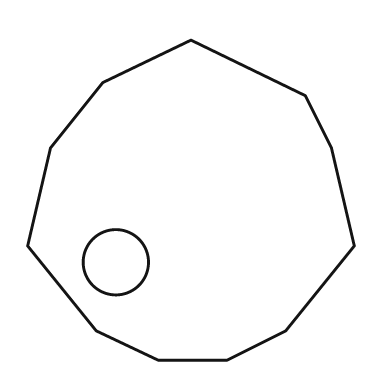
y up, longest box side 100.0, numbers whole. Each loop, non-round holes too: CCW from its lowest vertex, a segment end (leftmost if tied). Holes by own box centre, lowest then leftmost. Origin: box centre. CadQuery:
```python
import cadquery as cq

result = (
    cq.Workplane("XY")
    .moveTo(-10.0, -49.0)
    .lineTo(11.0, -49.0)
    .lineTo(29.0, -40.0)
    .lineTo(50.0, -14.0)
    .lineTo(43.0, 16.0)
    .lineTo(35.0, 32.0)
    .lineTo(0.0, 49.0)
    .lineTo(-27.0, 36.0)
    .lineTo(-43.0, 16.0)
    .lineTo(-50.0, -14.0)
    .lineTo(-29.0, -40.0)
    .close()
    .moveTo(-23.0, -19.0)
    .circle(10.0)
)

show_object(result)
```